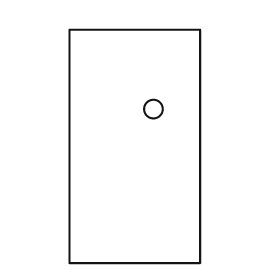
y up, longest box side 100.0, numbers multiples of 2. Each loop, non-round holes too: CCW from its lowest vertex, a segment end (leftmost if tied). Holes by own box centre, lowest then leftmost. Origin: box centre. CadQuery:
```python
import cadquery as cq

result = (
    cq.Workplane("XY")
    .moveTo(-28.0, -50.0)
    .lineTo(28.0, -50.0)
    .lineTo(28.0, 50.0)
    .lineTo(-28.0, 50.0)
    .close()
    .moveTo(8.0, 16.0)
    .circle(4.0)
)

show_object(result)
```